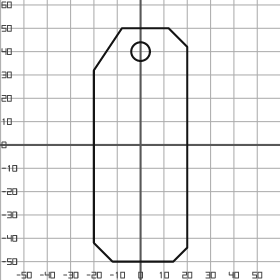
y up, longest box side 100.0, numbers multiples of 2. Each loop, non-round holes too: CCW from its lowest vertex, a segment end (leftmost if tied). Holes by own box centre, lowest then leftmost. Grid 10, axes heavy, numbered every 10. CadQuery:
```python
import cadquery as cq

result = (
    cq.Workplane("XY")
    .moveTo(-12.0, -50.0)
    .lineTo(14.0, -50.0)
    .lineTo(20.0, -44.0)
    .lineTo(20.0, 42.0)
    .lineTo(12.0, 50.0)
    .lineTo(-8.0, 50.0)
    .lineTo(-20.0, 32.0)
    .lineTo(-20.0, -42.0)
    .close()
    .moveTo(0.0, 40.0)
    .circle(4.0)
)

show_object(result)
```